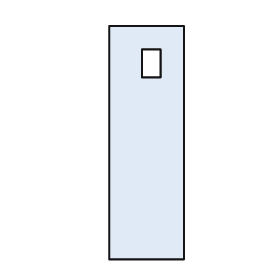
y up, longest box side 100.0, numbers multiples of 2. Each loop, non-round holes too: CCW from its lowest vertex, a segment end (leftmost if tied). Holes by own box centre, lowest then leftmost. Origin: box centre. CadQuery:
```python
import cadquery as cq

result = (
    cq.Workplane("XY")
    .moveTo(-16.0, -50.0)
    .lineTo(16.0, -50.0)
    .lineTo(16.0, 50.0)
    .lineTo(-16.0, 50.0)
    .close()
    .moveTo(-2.0, 28.0)
    .lineTo(6.0, 28.0)
    .lineTo(6.0, 40.0)
    .lineTo(-2.0, 40.0)
    .close()
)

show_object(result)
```